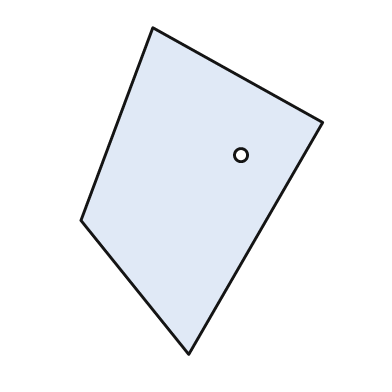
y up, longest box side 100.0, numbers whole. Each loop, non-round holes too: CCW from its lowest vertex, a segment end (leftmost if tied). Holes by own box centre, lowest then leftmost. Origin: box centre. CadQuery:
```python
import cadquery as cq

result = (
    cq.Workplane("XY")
    .moveTo(-4.0, -50.0)
    .lineTo(37.0, 21.0)
    .lineTo(-15.0, 50.0)
    .lineTo(-37.0, -9.0)
    .close()
    .moveTo(12.0, 11.0)
    .circle(2.0)
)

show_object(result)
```